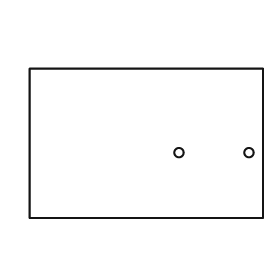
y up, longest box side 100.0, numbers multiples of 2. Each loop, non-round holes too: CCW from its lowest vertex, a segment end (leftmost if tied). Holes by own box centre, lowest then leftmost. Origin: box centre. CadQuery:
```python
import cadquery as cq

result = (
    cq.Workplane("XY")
    .moveTo(-50.0, -32.0)
    .lineTo(50.0, -32.0)
    .lineTo(50.0, 32.0)
    .lineTo(-50.0, 32.0)
    .close()
    .moveTo(14.0, -4.0)
    .circle(2.0)
    .moveTo(44.0, -4.0)
    .circle(2.0)
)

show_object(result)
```